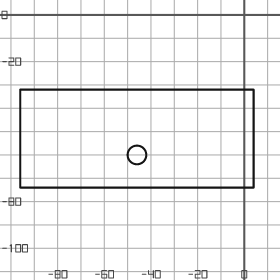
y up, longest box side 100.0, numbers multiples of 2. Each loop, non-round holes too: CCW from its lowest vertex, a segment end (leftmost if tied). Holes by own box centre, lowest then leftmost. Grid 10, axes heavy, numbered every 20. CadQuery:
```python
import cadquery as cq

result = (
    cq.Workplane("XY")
    .moveTo(-96.0, -74.0)
    .lineTo(4.0, -74.0)
    .lineTo(4.0, -32.0)
    .lineTo(-96.0, -32.0)
    .close()
    .moveTo(-46.0, -60.0)
    .circle(4.0)
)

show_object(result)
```